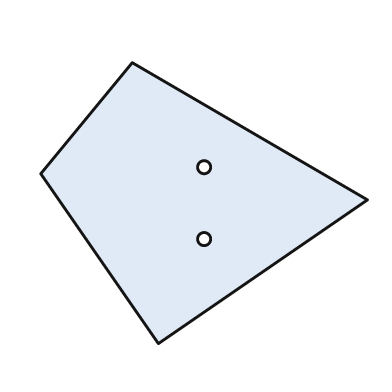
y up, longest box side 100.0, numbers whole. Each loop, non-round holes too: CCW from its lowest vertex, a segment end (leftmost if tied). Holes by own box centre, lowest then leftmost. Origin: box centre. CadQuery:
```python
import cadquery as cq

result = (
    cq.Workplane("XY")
    .moveTo(-14.0, -43.0)
    .lineTo(50.0, 1.0)
    .lineTo(-22.0, 43.0)
    .lineTo(-50.0, 9.0)
    .close()
    .moveTo(0.0, -11.0)
    .circle(2.0)
    .moveTo(0.0, 11.0)
    .circle(2.0)
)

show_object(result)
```